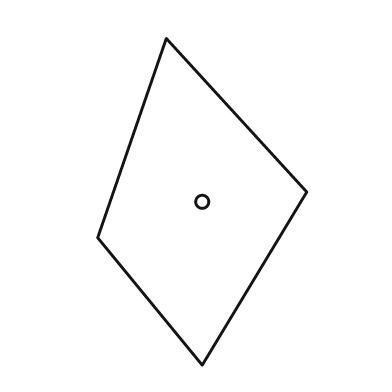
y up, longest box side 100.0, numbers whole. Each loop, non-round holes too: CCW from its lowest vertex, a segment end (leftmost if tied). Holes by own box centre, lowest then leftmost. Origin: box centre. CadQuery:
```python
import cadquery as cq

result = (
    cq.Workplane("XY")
    .moveTo(0.0, -50.0)
    .lineTo(32.0, 3.0)
    .lineTo(-11.0, 50.0)
    .lineTo(-32.0, -11.0)
    .close()
    .moveTo(0.0, 0.0)
    .circle(2.0)
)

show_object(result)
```